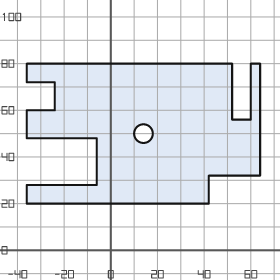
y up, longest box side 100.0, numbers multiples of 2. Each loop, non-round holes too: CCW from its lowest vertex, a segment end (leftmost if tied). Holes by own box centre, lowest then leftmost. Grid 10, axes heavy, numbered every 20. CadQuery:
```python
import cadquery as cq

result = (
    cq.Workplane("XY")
    .moveTo(-36.0, 20.0)
    .lineTo(42.0, 20.0)
    .lineTo(42.0, 32.0)
    .lineTo(64.0, 32.0)
    .lineTo(64.0, 80.0)
    .lineTo(60.0, 80.0)
    .lineTo(60.0, 56.0)
    .lineTo(52.0, 56.0)
    .lineTo(52.0, 80.0)
    .lineTo(-36.0, 80.0)
    .lineTo(-36.0, 72.0)
    .lineTo(-24.0, 72.0)
    .lineTo(-24.0, 60.0)
    .lineTo(-36.0, 60.0)
    .lineTo(-36.0, 48.0)
    .lineTo(-6.0, 48.0)
    .lineTo(-6.0, 28.0)
    .lineTo(-36.0, 28.0)
    .close()
    .moveTo(14.0, 50.0)
    .circle(4.0)
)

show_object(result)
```